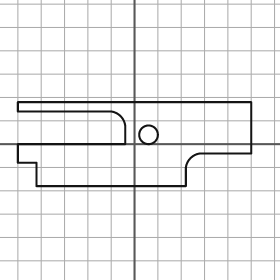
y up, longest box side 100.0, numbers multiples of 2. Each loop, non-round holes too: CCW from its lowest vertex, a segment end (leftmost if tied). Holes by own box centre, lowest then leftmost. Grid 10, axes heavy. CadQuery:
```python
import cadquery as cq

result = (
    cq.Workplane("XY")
    .moveTo(-42.0, -18.0)
    .lineTo(22.0, -18.0)
    .lineTo(22.0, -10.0)
    .threePointArc((24.0, -6.0), (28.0, -4.0))
    .lineTo(50.0, -4.0)
    .lineTo(50.0, 18.0)
    .lineTo(-50.0, 18.0)
    .lineTo(-50.0, 14.0)
    .lineTo(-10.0, 14.0)
    .threePointArc((-6.0, 12.0), (-4.0, 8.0))
    .lineTo(-4.0, 0.0)
    .lineTo(-50.0, 0.0)
    .lineTo(-50.0, -8.0)
    .lineTo(-42.0, -8.0)
    .close()
    .moveTo(6.0, 4.0)
    .circle(4.0)
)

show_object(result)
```